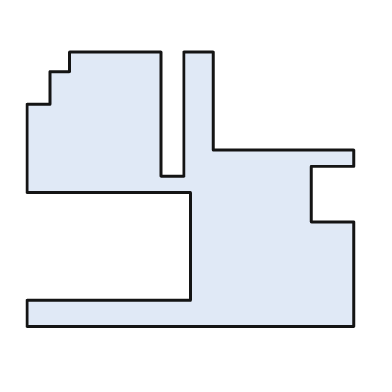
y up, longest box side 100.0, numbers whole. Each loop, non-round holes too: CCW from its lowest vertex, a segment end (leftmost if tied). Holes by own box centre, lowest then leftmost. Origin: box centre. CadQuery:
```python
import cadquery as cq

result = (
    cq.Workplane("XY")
    .moveTo(-50.0, -42.0)
    .lineTo(50.0, -42.0)
    .lineTo(50.0, -10.0)
    .lineTo(37.0, -10.0)
    .lineTo(37.0, 7.0)
    .lineTo(50.0, 7.0)
    .lineTo(50.0, 12.0)
    .lineTo(7.0, 12.0)
    .lineTo(7.0, 42.0)
    .lineTo(-2.0, 42.0)
    .lineTo(-2.0, 4.0)
    .lineTo(-9.0, 4.0)
    .lineTo(-9.0, 42.0)
    .lineTo(-37.0, 42.0)
    .lineTo(-37.0, 36.0)
    .lineTo(-43.0, 36.0)
    .lineTo(-43.0, 26.0)
    .lineTo(-50.0, 26.0)
    .lineTo(-50.0, -1.0)
    .lineTo(0.0, -1.0)
    .lineTo(0.0, -34.0)
    .lineTo(-50.0, -34.0)
    .close()
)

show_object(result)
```